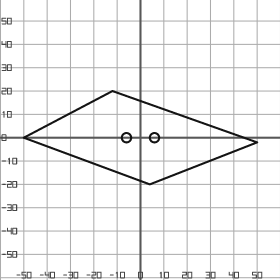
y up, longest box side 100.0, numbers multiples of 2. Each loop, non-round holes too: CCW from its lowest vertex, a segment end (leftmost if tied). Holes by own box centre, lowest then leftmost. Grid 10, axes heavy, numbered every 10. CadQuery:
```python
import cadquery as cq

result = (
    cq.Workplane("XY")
    .moveTo(4.0, -20.0)
    .lineTo(50.0, -2.0)
    .lineTo(-12.0, 20.0)
    .lineTo(-50.0, 0.0)
    .close()
    .moveTo(-6.0, 0.0)
    .circle(2.0)
    .moveTo(6.0, 0.0)
    .circle(2.0)
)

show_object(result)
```